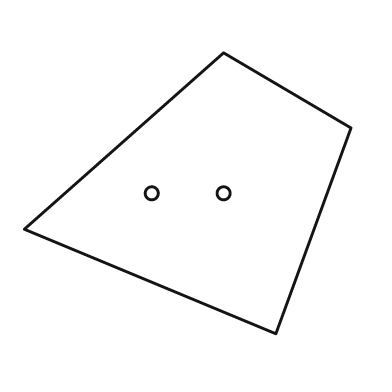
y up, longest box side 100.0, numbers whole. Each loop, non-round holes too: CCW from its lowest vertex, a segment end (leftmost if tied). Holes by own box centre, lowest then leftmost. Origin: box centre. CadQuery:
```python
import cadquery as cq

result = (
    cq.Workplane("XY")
    .moveTo(27.0, -43.0)
    .lineTo(50.0, 20.0)
    .lineTo(11.0, 43.0)
    .lineTo(-50.0, -11.0)
    .close()
    .moveTo(-11.0, 0.0)
    .circle(2.0)
    .moveTo(11.0, 0.0)
    .circle(2.0)
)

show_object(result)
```